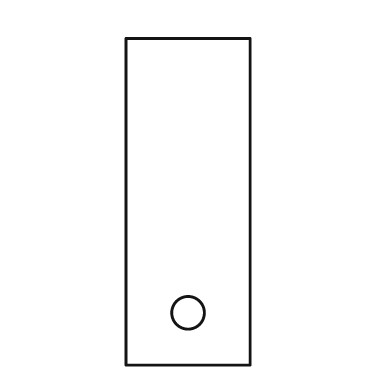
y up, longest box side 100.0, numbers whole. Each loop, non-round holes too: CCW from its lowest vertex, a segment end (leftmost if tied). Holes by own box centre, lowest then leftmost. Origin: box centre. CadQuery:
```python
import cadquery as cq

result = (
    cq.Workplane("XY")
    .moveTo(-19.0, -50.0)
    .lineTo(19.0, -50.0)
    .lineTo(19.0, 50.0)
    .lineTo(-19.0, 50.0)
    .close()
    .moveTo(0.0, -34.0)
    .circle(5.0)
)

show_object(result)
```